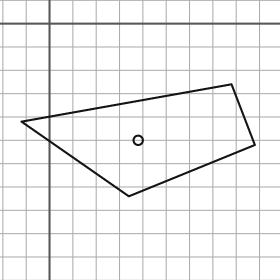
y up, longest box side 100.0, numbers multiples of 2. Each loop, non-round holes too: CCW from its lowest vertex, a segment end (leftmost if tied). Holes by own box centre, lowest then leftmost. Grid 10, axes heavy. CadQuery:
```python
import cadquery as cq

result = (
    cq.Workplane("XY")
    .moveTo(34.0, -74.0)
    .lineTo(88.0, -52.0)
    .lineTo(78.0, -26.0)
    .lineTo(-12.0, -42.0)
    .close()
    .moveTo(38.0, -50.0)
    .circle(2.0)
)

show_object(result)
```